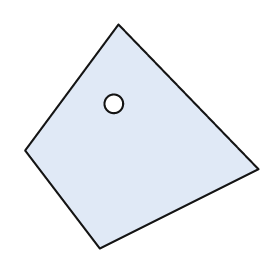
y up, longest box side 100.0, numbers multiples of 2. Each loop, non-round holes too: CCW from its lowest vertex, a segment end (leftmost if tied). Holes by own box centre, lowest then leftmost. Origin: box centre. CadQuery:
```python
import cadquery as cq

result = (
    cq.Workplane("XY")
    .moveTo(-18.0, -48.0)
    .lineTo(50.0, -14.0)
    .lineTo(-10.0, 48.0)
    .lineTo(-50.0, -6.0)
    .close()
    .moveTo(-12.0, 14.0)
    .circle(4.0)
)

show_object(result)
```